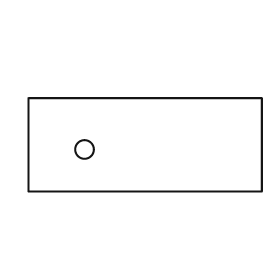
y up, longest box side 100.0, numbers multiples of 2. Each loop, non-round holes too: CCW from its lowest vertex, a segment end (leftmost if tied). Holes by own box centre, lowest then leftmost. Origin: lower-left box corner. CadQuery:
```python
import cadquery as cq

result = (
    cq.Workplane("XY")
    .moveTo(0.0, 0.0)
    .lineTo(100.0, 0.0)
    .lineTo(100.0, 40.0)
    .lineTo(0.0, 40.0)
    .close()
    .moveTo(24.0, 18.0)
    .circle(4.0)
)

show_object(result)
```